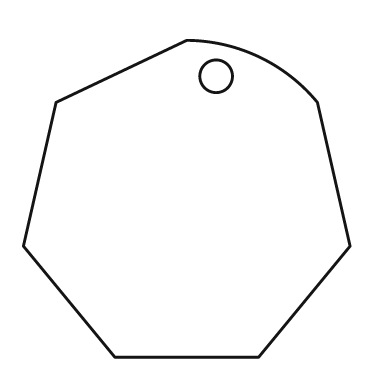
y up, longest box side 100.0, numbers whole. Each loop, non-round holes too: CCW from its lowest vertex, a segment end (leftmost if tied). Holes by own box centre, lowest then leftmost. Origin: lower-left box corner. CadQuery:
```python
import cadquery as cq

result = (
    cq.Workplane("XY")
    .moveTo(28.0, 0.0)
    .lineTo(72.0, 0.0)
    .lineTo(100.0, 34.0)
    .lineTo(90.0, 78.0)
    .threePointArc((72.0, 92.0), (50.0, 97.0))
    .lineTo(10.0, 78.0)
    .lineTo(0.0, 34.0)
    .close()
    .moveTo(59.0, 86.0)
    .circle(5.0)
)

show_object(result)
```